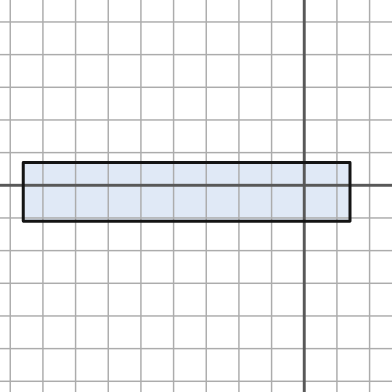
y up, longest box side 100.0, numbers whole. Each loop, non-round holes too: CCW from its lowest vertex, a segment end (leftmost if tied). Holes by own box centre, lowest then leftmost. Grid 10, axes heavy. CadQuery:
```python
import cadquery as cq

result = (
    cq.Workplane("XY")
    .moveTo(-86.0, -11.0)
    .lineTo(14.0, -11.0)
    .lineTo(14.0, 7.0)
    .lineTo(-86.0, 7.0)
    .close()
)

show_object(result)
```